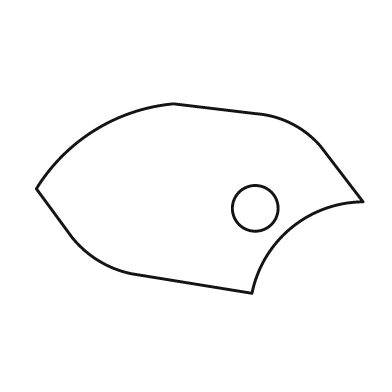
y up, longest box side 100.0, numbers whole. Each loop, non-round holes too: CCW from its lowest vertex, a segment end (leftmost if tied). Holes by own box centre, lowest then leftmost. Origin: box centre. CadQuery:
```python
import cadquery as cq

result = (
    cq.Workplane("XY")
    .moveTo(16.0, -29.0)
    .threePointArc((28.0, -9.0), (50.0, -1.0))
    .lineTo(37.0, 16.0)
    .threePointArc((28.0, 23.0), (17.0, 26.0))
    .lineTo(-8.0, 29.0)
    .threePointArc((-32.0, 21.0), (-50.0, 3.0))
    .lineTo(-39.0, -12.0)
    .threePointArc((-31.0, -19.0), (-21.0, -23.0))
    .close()
    .moveTo(17.0, -3.0)
    .circle(7.0)
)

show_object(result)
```